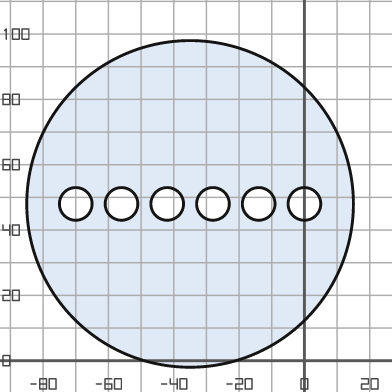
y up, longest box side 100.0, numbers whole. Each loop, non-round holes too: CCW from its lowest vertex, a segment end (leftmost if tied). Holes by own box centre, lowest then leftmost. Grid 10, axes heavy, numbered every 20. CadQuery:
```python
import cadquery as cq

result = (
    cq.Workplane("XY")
    .moveTo(-35.0, 48.0)
    .circle(50.0)
    .moveTo(-70.0, 48.0)
    .circle(5.0)
    .moveTo(-56.0, 48.0)
    .circle(5.0)
    .moveTo(-42.0, 48.0)
    .circle(5.0)
    .moveTo(-28.0, 48.0)
    .circle(5.0)
    .moveTo(-14.0, 48.0)
    .circle(5.0)
    .moveTo(0.0, 48.0)
    .circle(5.0)
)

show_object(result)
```